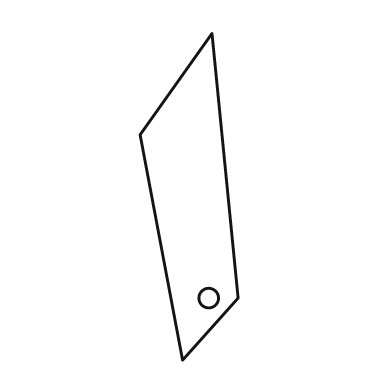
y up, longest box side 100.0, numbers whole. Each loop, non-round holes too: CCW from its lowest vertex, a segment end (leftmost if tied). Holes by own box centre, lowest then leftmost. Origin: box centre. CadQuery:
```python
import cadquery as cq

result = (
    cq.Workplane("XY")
    .moveTo(-2.0, -50.0)
    .lineTo(15.0, -31.0)
    .lineTo(7.0, 50.0)
    .lineTo(-15.0, 19.0)
    .close()
    .moveTo(6.0, -31.0)
    .circle(3.0)
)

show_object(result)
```